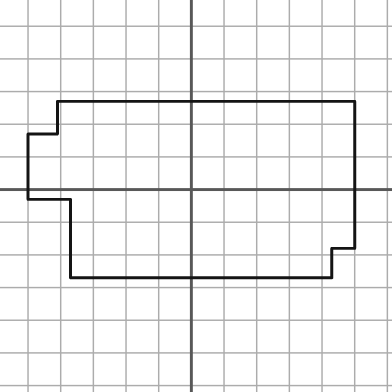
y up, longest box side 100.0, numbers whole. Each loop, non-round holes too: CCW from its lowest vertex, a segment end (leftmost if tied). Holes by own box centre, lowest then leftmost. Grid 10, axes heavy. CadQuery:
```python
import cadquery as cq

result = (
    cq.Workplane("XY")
    .moveTo(-37.0, -27.0)
    .lineTo(43.0, -27.0)
    .lineTo(43.0, -18.0)
    .lineTo(50.0, -18.0)
    .lineTo(50.0, 27.0)
    .lineTo(-41.0, 27.0)
    .lineTo(-41.0, 17.0)
    .lineTo(-50.0, 17.0)
    .lineTo(-50.0, -3.0)
    .lineTo(-37.0, -3.0)
    .close()
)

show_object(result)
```